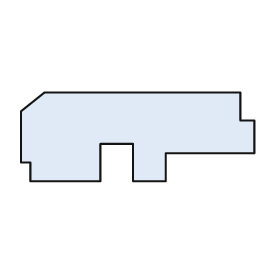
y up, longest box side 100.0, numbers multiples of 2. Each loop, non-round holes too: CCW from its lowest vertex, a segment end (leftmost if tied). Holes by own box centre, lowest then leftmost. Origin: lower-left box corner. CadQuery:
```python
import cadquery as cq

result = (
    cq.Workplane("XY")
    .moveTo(4.0, 0.0)
    .lineTo(34.0, 0.0)
    .lineTo(34.0, 16.0)
    .lineTo(48.0, 16.0)
    .lineTo(48.0, 0.0)
    .lineTo(62.0, 0.0)
    .lineTo(62.0, 12.0)
    .lineTo(100.0, 12.0)
    .lineTo(100.0, 26.0)
    .lineTo(94.0, 26.0)
    .lineTo(94.0, 38.0)
    .lineTo(10.0, 38.0)
    .lineTo(0.0, 30.0)
    .lineTo(0.0, 8.0)
    .lineTo(4.0, 8.0)
    .close()
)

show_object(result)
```